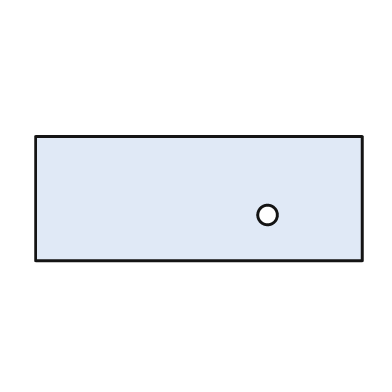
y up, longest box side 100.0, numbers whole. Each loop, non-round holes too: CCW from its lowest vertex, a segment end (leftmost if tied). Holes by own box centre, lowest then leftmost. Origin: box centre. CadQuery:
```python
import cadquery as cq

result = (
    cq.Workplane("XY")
    .moveTo(-50.0, -19.0)
    .lineTo(50.0, -19.0)
    .lineTo(50.0, 19.0)
    .lineTo(-50.0, 19.0)
    .close()
    .moveTo(21.0, -5.0)
    .circle(3.0)
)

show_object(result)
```